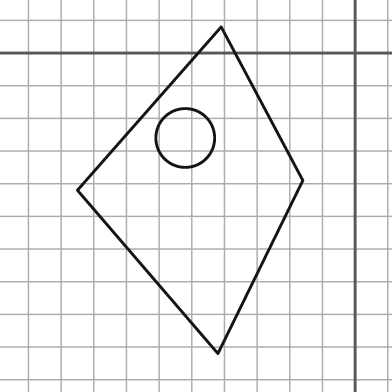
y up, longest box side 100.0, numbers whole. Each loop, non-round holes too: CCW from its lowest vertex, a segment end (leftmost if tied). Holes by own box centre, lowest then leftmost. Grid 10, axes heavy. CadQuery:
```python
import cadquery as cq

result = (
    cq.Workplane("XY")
    .moveTo(-42.0, -92.0)
    .lineTo(-16.0, -39.0)
    .lineTo(-41.0, 8.0)
    .lineTo(-85.0, -42.0)
    .close()
    .moveTo(-52.0, -26.0)
    .circle(9.0)
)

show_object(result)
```